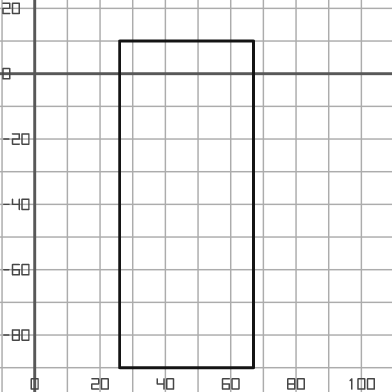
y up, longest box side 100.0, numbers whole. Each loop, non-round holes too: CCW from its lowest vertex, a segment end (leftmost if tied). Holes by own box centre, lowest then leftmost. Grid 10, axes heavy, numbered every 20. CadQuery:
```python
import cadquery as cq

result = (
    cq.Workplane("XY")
    .moveTo(26.0, -90.0)
    .lineTo(67.0, -90.0)
    .lineTo(67.0, 10.0)
    .lineTo(26.0, 10.0)
    .close()
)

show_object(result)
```